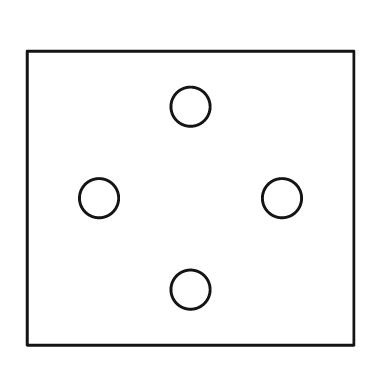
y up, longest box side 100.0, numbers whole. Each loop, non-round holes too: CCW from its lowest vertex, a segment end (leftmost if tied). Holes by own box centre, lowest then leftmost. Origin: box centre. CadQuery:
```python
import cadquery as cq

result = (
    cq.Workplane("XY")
    .moveTo(-50.0, -45.0)
    .lineTo(50.0, -45.0)
    .lineTo(50.0, 45.0)
    .lineTo(-50.0, 45.0)
    .close()
    .moveTo(0.0, -28.0)
    .circle(6.0)
    .moveTo(-28.0, 0.0)
    .circle(6.0)
    .moveTo(28.0, 0.0)
    .circle(6.0)
    .moveTo(0.0, 28.0)
    .circle(6.0)
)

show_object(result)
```